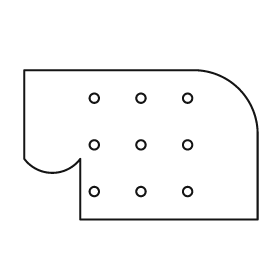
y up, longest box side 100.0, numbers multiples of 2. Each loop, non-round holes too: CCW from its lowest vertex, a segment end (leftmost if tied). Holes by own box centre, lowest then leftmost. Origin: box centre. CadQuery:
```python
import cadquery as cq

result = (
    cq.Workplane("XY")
    .moveTo(-26.0, -32.0)
    .lineTo(50.0, -32.0)
    .lineTo(50.0, 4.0)
    .threePointArc((42.0, 24.0), (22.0, 32.0))
    .lineTo(-50.0, 32.0)
    .lineTo(-50.0, -6.0)
    .threePointArc((-38.0, -12.0), (-26.0, -6.0))
    .close()
    .moveTo(-20.0, -20.0)
    .circle(2.0)
    .moveTo(0.0, -20.0)
    .circle(2.0)
    .moveTo(20.0, -20.0)
    .circle(2.0)
    .moveTo(-20.0, 0.0)
    .circle(2.0)
    .moveTo(0.0, 0.0)
    .circle(2.0)
    .moveTo(20.0, 0.0)
    .circle(2.0)
    .moveTo(-20.0, 20.0)
    .circle(2.0)
    .moveTo(0.0, 20.0)
    .circle(2.0)
    .moveTo(20.0, 20.0)
    .circle(2.0)
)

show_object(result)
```